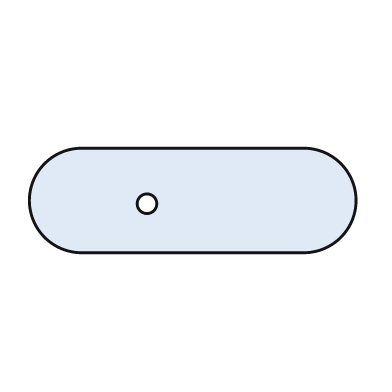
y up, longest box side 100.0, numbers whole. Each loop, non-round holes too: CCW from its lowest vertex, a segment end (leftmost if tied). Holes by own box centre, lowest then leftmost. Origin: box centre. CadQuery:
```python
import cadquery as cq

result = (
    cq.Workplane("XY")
    .moveTo(-34.0, -16.0)
    .lineTo(34.0, -16.0)
    .threePointArc((50.0, 0.0), (34.0, 16.0))
    .lineTo(-34.0, 16.0)
    .threePointArc((-50.0, 0.0), (-34.0, -16.0))
    .close()
    .moveTo(-14.0, -1.0)
    .circle(3.0)
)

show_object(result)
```